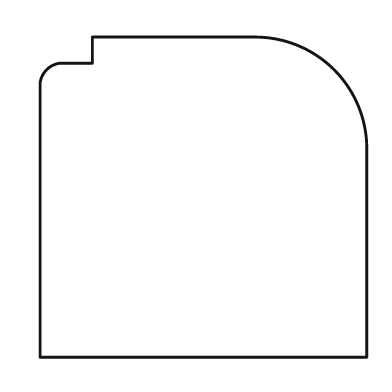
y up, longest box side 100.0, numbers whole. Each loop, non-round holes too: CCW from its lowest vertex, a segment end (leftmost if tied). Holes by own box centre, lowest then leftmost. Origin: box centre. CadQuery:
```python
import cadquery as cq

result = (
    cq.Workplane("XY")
    .moveTo(-50.0, -49.0)
    .lineTo(50.0, -49.0)
    .lineTo(50.0, 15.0)
    .threePointArc((40.0, 39.0), (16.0, 49.0))
    .lineTo(-34.0, 49.0)
    .lineTo(-34.0, 41.0)
    .lineTo(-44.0, 41.0)
    .threePointArc((-48.0, 39.0), (-50.0, 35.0))
    .close()
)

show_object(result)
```